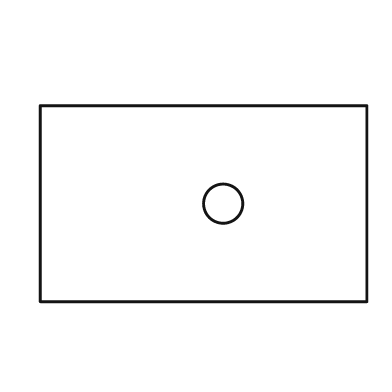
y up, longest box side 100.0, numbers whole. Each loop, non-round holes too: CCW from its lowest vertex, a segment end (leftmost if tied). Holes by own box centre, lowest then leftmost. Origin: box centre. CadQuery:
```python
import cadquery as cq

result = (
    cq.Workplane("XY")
    .moveTo(-50.0, -30.0)
    .lineTo(50.0, -30.0)
    .lineTo(50.0, 30.0)
    .lineTo(-50.0, 30.0)
    .close()
    .moveTo(6.0, 0.0)
    .circle(6.0)
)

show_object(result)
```